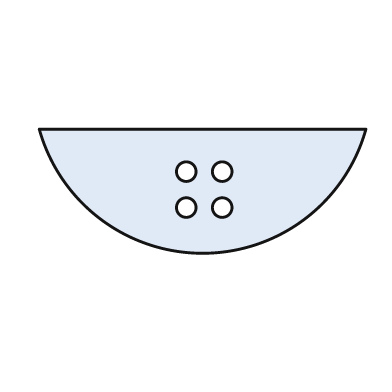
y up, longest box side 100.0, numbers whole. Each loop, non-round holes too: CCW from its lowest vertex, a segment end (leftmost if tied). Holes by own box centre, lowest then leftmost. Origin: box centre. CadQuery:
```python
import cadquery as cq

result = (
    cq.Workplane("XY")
    .moveTo(-50.0, 19.0)
    .threePointArc((0.0, -19.0), (50.0, 19.0))
    .close()
    .moveTo(-5.0, -5.0)
    .circle(3.0)
    .moveTo(6.0, -5.0)
    .circle(3.0)
    .moveTo(-5.0, 6.0)
    .circle(3.0)
    .moveTo(6.0, 6.0)
    .circle(3.0)
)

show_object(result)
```